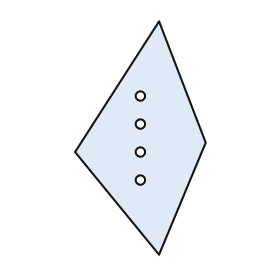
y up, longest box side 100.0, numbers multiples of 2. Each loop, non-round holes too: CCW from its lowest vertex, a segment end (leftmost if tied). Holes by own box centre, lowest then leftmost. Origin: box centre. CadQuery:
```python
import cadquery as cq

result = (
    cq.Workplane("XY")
    .moveTo(8.0, -50.0)
    .lineTo(28.0, -2.0)
    .lineTo(8.0, 50.0)
    .lineTo(-28.0, -6.0)
    .close()
    .moveTo(0.0, -18.0)
    .circle(2.0)
    .moveTo(0.0, -6.0)
    .circle(2.0)
    .moveTo(0.0, 6.0)
    .circle(2.0)
    .moveTo(0.0, 18.0)
    .circle(2.0)
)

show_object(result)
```